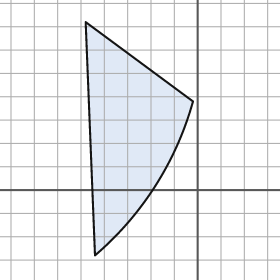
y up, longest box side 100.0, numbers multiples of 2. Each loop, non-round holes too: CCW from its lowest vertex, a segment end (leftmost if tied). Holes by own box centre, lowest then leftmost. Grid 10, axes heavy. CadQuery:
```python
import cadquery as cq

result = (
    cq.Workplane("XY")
    .moveTo(-44.0, -28.0)
    .threePointArc((-18.0, 2.0), (-2.0, 38.0))
    .lineTo(-48.0, 72.0)
    .close()
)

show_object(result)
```